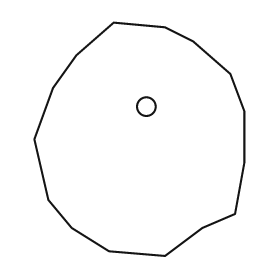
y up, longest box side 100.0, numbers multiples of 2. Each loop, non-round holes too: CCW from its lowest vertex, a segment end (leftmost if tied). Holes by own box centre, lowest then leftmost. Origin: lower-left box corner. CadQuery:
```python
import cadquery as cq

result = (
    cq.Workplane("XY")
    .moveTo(56.0, 0.0)
    .lineTo(72.0, 12.0)
    .lineTo(86.0, 18.0)
    .lineTo(90.0, 40.0)
    .lineTo(90.0, 62.0)
    .lineTo(84.0, 78.0)
    .lineTo(68.0, 92.0)
    .lineTo(56.0, 98.0)
    .lineTo(34.0, 100.0)
    .lineTo(18.0, 86.0)
    .lineTo(8.0, 72.0)
    .lineTo(0.0, 50.0)
    .lineTo(6.0, 24.0)
    .lineTo(16.0, 12.0)
    .lineTo(32.0, 2.0)
    .close()
    .moveTo(48.0, 64.0)
    .circle(4.0)
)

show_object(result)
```